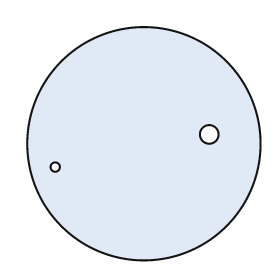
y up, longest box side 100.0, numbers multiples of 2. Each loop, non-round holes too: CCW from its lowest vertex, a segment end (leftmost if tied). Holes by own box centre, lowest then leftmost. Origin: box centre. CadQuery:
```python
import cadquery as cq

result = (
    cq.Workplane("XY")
    .moveTo(0.0, 0.0)
    .circle(50.0)
    .moveTo(-38.0, -10.0)
    .circle(2.0)
    .moveTo(28.0, 4.0)
    .circle(4.0)
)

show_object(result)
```